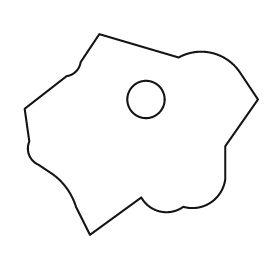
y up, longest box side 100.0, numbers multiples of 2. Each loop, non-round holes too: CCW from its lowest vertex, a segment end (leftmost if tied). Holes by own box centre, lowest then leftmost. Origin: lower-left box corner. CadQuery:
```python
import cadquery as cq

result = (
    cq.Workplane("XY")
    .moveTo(28.0, 0.0)
    .lineTo(50.0, 16.0)
    .threePointArc((58.0, 10.0), (68.0, 12.0))
    .threePointArc((80.0, 14.0), (86.0, 24.0))
    .lineTo(86.0, 38.0)
    .lineTo(100.0, 58.0)
    .lineTo(92.0, 70.0)
    .threePointArc((80.0, 78.0), (66.0, 76.0))
    .lineTo(32.0, 86.0)
    .lineTo(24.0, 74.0)
    .threePointArc((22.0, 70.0), (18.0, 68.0))
    .lineTo(0.0, 54.0)
    .lineTo(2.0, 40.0)
    .threePointArc((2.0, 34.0), (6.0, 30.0))
    .lineTo(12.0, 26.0)
    .threePointArc((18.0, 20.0), (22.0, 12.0))
    .close()
    .moveTo(52.0, 58.0)
    .circle(8.0)
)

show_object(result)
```